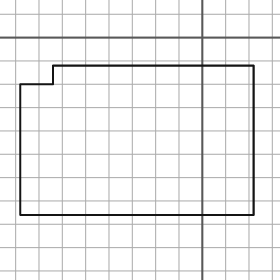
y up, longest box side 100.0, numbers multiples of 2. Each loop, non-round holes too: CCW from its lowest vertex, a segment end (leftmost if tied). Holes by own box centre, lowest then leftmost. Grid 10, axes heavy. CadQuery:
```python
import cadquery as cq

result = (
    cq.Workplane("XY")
    .moveTo(-78.0, -76.0)
    .lineTo(22.0, -76.0)
    .lineTo(22.0, -12.0)
    .lineTo(-64.0, -12.0)
    .lineTo(-64.0, -20.0)
    .lineTo(-78.0, -20.0)
    .close()
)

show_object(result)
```